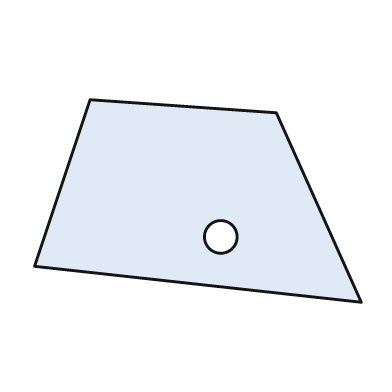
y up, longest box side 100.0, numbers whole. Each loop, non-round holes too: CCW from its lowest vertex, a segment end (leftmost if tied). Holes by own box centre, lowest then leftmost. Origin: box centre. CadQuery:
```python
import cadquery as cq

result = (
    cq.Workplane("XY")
    .moveTo(50.0, -31.0)
    .lineTo(24.0, 27.0)
    .lineTo(-33.0, 31.0)
    .lineTo(-50.0, -20.0)
    .close()
    .moveTo(7.0, -11.0)
    .circle(5.0)
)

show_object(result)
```